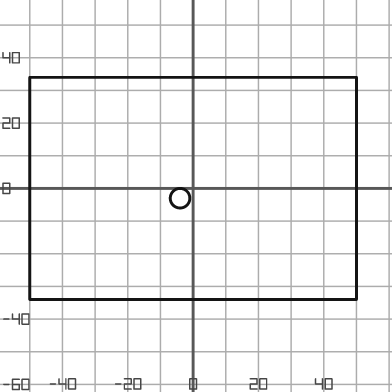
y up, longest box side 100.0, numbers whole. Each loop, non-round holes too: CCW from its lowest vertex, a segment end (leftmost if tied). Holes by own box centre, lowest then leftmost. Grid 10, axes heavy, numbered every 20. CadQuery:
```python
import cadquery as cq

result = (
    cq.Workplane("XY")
    .moveTo(-50.0, -34.0)
    .lineTo(50.0, -34.0)
    .lineTo(50.0, 34.0)
    .lineTo(-50.0, 34.0)
    .close()
    .moveTo(-4.0, -3.0)
    .circle(3.0)
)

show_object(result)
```